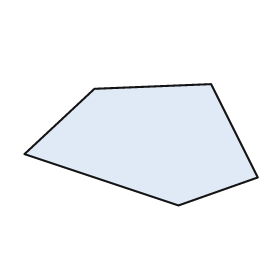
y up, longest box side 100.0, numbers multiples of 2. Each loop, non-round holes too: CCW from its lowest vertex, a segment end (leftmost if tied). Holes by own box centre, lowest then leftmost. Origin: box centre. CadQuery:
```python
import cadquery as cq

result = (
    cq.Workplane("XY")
    .moveTo(16.0, -26.0)
    .lineTo(50.0, -14.0)
    .lineTo(30.0, 26.0)
    .lineTo(-20.0, 24.0)
    .lineTo(-50.0, -4.0)
    .close()
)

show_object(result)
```